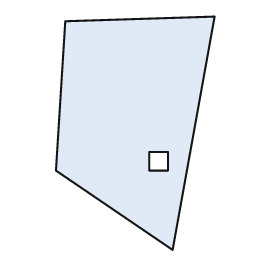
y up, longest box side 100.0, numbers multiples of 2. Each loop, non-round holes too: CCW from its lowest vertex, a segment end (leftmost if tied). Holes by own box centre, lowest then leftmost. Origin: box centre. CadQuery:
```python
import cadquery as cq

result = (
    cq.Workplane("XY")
    .moveTo(16.0, -50.0)
    .lineTo(34.0, 50.0)
    .lineTo(-30.0, 48.0)
    .lineTo(-34.0, -16.0)
    .close()
    .moveTo(6.0, -16.0)
    .lineTo(14.0, -16.0)
    .lineTo(14.0, -8.0)
    .lineTo(6.0, -8.0)
    .close()
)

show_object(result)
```